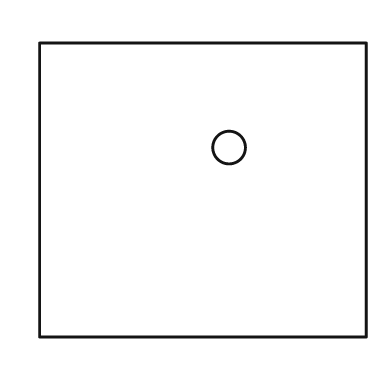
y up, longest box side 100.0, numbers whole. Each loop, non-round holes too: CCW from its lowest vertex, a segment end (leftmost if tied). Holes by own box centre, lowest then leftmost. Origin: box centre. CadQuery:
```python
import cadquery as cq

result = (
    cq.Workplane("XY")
    .moveTo(-50.0, -45.0)
    .lineTo(50.0, -45.0)
    .lineTo(50.0, 45.0)
    .lineTo(-50.0, 45.0)
    .close()
    .moveTo(8.0, 13.0)
    .circle(5.0)
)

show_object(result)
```